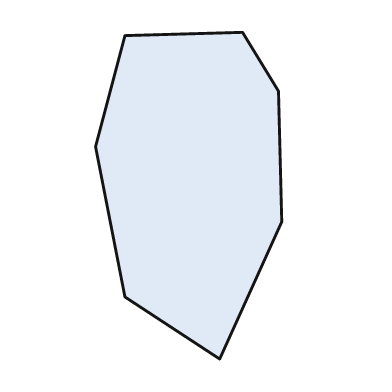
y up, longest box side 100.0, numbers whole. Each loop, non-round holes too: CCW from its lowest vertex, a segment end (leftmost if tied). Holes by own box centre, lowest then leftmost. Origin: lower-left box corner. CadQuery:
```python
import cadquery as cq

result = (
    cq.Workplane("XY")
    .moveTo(38.0, 0.0)
    .lineTo(57.0, 42.0)
    .lineTo(56.0, 82.0)
    .lineTo(45.0, 100.0)
    .lineTo(9.0, 99.0)
    .lineTo(0.0, 65.0)
    .lineTo(9.0, 19.0)
    .close()
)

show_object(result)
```